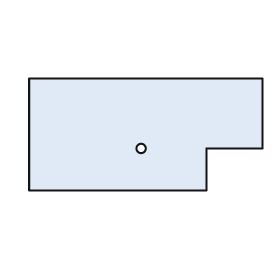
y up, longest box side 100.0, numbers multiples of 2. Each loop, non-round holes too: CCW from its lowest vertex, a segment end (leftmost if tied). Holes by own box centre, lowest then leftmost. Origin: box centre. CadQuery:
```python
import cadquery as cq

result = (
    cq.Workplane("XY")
    .moveTo(-50.0, -24.0)
    .lineTo(26.0, -24.0)
    .lineTo(26.0, -6.0)
    .lineTo(50.0, -6.0)
    .lineTo(50.0, 24.0)
    .lineTo(-50.0, 24.0)
    .close()
    .moveTo(-2.0, -6.0)
    .circle(2.0)
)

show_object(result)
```